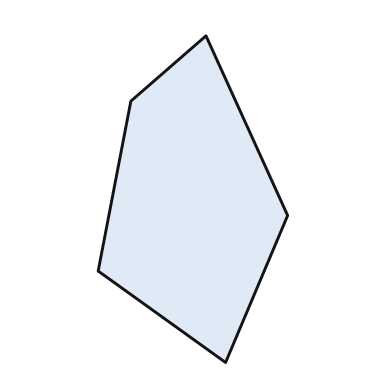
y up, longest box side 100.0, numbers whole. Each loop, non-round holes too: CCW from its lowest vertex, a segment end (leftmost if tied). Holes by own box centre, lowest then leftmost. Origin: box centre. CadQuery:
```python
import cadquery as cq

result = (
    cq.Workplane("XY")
    .moveTo(10.0, -50.0)
    .lineTo(29.0, -5.0)
    .lineTo(4.0, 50.0)
    .lineTo(-19.0, 30.0)
    .lineTo(-29.0, -22.0)
    .close()
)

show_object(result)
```